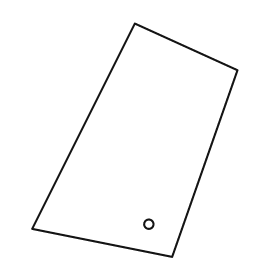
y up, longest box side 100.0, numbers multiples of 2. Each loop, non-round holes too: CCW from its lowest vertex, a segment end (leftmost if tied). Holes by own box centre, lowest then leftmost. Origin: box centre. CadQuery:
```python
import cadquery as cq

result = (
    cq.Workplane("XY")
    .moveTo(16.0, -50.0)
    .lineTo(44.0, 30.0)
    .lineTo(0.0, 50.0)
    .lineTo(-44.0, -38.0)
    .close()
    .moveTo(6.0, -36.0)
    .circle(2.0)
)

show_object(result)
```